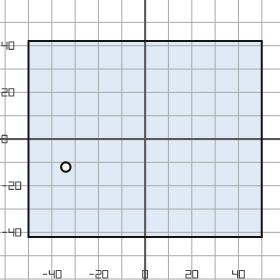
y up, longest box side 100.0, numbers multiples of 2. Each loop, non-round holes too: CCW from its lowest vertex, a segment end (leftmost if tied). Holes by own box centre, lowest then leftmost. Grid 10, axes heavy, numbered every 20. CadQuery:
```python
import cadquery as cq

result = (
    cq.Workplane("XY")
    .moveTo(-50.0, -42.0)
    .lineTo(50.0, -42.0)
    .lineTo(50.0, 42.0)
    .lineTo(-50.0, 42.0)
    .close()
    .moveTo(-34.0, -12.0)
    .circle(2.0)
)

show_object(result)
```